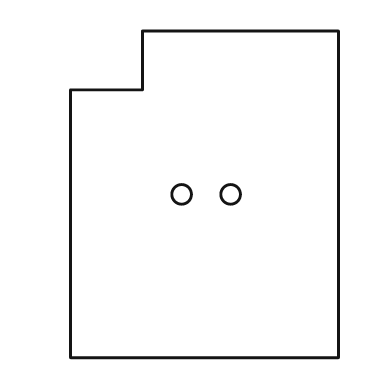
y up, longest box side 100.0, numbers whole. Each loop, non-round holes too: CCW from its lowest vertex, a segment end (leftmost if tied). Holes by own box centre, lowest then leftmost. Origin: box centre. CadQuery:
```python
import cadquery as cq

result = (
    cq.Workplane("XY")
    .moveTo(-41.0, -50.0)
    .lineTo(41.0, -50.0)
    .lineTo(41.0, 50.0)
    .lineTo(-19.0, 50.0)
    .lineTo(-19.0, 32.0)
    .lineTo(-41.0, 32.0)
    .close()
    .moveTo(-7.0, 0.0)
    .circle(3.0)
    .moveTo(8.0, 0.0)
    .circle(3.0)
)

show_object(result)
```